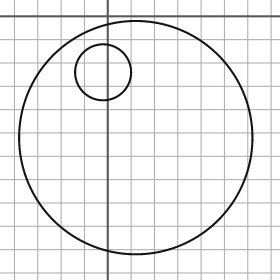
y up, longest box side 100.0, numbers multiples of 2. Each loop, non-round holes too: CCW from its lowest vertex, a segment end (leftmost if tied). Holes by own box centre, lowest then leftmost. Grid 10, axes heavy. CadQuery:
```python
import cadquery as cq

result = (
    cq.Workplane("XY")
    .moveTo(12.0, -52.0)
    .circle(50.0)
    .moveTo(-2.0, -24.0)
    .circle(12.0)
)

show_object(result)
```